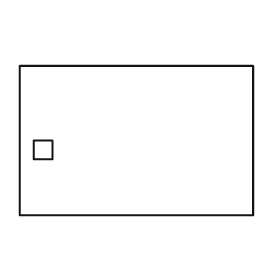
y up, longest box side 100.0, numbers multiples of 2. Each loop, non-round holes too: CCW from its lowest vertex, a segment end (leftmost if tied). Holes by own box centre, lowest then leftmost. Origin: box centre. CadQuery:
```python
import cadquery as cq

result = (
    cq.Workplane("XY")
    .moveTo(-50.0, -32.0)
    .lineTo(50.0, -32.0)
    .lineTo(50.0, 32.0)
    .lineTo(-50.0, 32.0)
    .close()
    .moveTo(-44.0, -8.0)
    .lineTo(-36.0, -8.0)
    .lineTo(-36.0, 0.0)
    .lineTo(-44.0, 0.0)
    .close()
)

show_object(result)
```